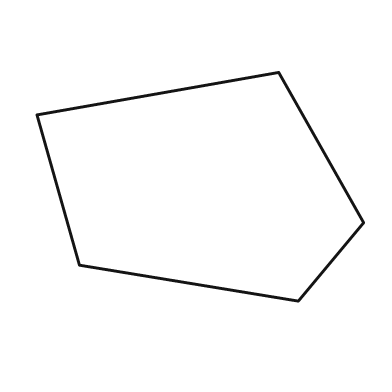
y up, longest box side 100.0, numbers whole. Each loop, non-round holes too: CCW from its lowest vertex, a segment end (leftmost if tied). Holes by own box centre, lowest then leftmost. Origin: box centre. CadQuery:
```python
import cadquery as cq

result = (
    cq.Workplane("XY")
    .moveTo(30.0, -35.0)
    .lineTo(50.0, -11.0)
    .lineTo(24.0, 35.0)
    .lineTo(-50.0, 22.0)
    .lineTo(-37.0, -24.0)
    .close()
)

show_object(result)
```